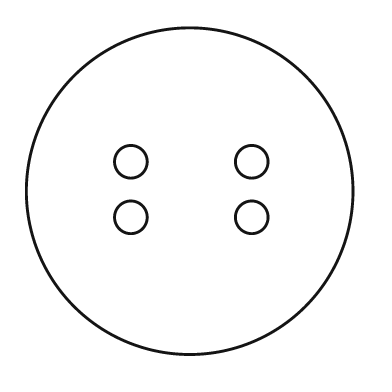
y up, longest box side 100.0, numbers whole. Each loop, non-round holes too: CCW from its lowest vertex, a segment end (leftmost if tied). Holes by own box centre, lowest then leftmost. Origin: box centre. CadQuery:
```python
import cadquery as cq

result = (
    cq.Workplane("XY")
    .moveTo(0.0, 0.0)
    .circle(50.0)
    .moveTo(-18.0, -8.0)
    .circle(5.0)
    .moveTo(19.0, -8.0)
    .circle(5.0)
    .moveTo(-18.0, 9.0)
    .circle(5.0)
    .moveTo(19.0, 9.0)
    .circle(5.0)
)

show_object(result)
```